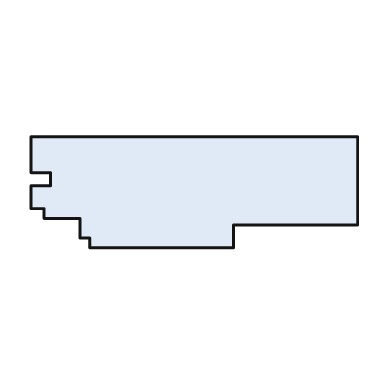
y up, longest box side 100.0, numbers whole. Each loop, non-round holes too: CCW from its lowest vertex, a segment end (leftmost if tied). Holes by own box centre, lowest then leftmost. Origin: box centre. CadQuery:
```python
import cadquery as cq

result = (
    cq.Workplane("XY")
    .moveTo(-32.0, -17.0)
    .lineTo(12.0, -17.0)
    .lineTo(12.0, -10.0)
    .lineTo(50.0, -10.0)
    .lineTo(50.0, 17.0)
    .lineTo(-50.0, 17.0)
    .lineTo(-50.0, 6.0)
    .lineTo(-44.0, 6.0)
    .lineTo(-44.0, 2.0)
    .lineTo(-50.0, 2.0)
    .lineTo(-50.0, -5.0)
    .lineTo(-46.0, -5.0)
    .lineTo(-46.0, -8.0)
    .lineTo(-35.0, -8.0)
    .lineTo(-35.0, -14.0)
    .lineTo(-32.0, -14.0)
    .close()
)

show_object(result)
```